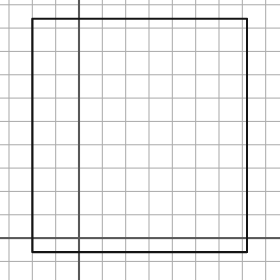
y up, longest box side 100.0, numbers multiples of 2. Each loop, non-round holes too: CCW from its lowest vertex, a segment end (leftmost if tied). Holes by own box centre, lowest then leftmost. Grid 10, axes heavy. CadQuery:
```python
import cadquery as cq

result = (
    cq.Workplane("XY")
    .moveTo(-20.0, -6.0)
    .lineTo(72.0, -6.0)
    .lineTo(72.0, 94.0)
    .lineTo(-20.0, 94.0)
    .close()
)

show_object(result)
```